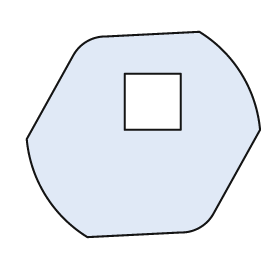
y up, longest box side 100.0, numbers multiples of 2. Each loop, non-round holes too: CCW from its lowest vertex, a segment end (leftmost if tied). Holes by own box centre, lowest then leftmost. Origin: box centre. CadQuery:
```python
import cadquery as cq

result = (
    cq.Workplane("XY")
    .moveTo(-24.0, -44.0)
    .lineTo(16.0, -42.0)
    .threePointArc((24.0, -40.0), (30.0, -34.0))
    .lineTo(50.0, 2.0)
    .threePointArc((42.0, 26.0), (24.0, 44.0))
    .lineTo(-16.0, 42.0)
    .threePointArc((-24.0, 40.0), (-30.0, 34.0))
    .lineTo(-50.0, -2.0)
    .threePointArc((-42.0, -26.0), (-24.0, -44.0))
    .close()
    .moveTo(-8.0, 2.0)
    .lineTo(16.0, 2.0)
    .lineTo(16.0, 26.0)
    .lineTo(-8.0, 26.0)
    .close()
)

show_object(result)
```